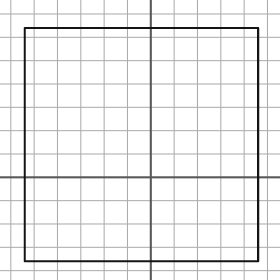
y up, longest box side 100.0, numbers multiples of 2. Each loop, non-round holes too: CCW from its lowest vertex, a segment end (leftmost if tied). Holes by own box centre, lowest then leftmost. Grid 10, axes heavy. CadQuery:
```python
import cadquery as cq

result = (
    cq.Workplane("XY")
    .moveTo(-54.0, -36.0)
    .lineTo(46.0, -36.0)
    .lineTo(46.0, 64.0)
    .lineTo(-54.0, 64.0)
    .close()
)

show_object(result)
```